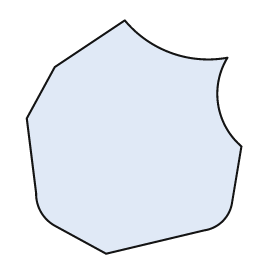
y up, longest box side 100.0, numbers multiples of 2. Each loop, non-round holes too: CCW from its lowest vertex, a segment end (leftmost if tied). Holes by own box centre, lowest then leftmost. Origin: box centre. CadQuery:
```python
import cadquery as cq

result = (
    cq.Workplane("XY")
    .moveTo(-12.0, -50.0)
    .lineTo(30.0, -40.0)
    .threePointArc((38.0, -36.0), (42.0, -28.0))
    .lineTo(46.0, -4.0)
    .threePointArc((36.0, 14.0), (40.0, 34.0))
    .threePointArc((16.0, 36.0), (-4.0, 50.0))
    .lineTo(-34.0, 30.0)
    .lineTo(-46.0, 8.0)
    .lineTo(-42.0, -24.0)
    .threePointArc((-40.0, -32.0), (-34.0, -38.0))
    .close()
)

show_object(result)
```